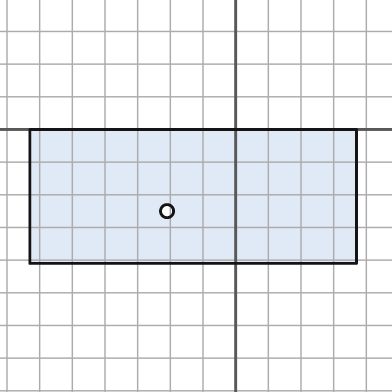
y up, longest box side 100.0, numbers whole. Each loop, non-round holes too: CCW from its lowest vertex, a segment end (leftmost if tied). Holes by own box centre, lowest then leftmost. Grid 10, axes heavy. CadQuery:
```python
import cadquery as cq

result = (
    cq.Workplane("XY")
    .moveTo(-63.0, -41.0)
    .lineTo(37.0, -41.0)
    .lineTo(37.0, 0.0)
    .lineTo(-63.0, 0.0)
    .close()
    .moveTo(-21.0, -25.0)
    .circle(2.0)
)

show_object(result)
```